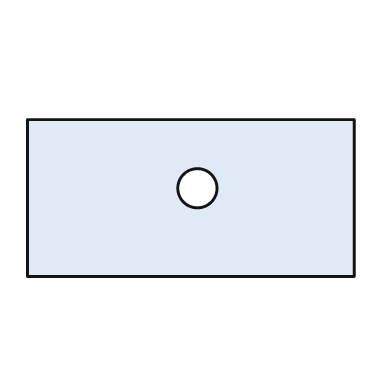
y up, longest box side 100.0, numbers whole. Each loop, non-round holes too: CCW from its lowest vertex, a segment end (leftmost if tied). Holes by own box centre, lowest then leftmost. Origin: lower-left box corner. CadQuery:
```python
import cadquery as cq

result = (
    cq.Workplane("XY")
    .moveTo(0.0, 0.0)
    .lineTo(100.0, 0.0)
    .lineTo(100.0, 48.0)
    .lineTo(0.0, 48.0)
    .close()
    .moveTo(52.0, 27.0)
    .circle(6.0)
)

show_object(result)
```